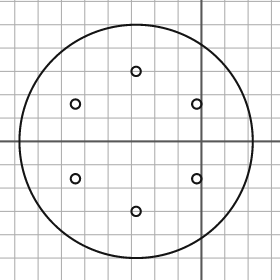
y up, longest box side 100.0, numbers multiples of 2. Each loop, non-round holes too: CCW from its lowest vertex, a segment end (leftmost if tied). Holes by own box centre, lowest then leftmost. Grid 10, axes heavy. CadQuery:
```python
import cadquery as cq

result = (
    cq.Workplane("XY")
    .moveTo(-28.0, 0.0)
    .circle(50.0)
    .moveTo(-28.0, -30.0)
    .circle(2.0)
    .moveTo(-54.0, -16.0)
    .circle(2.0)
    .moveTo(-2.0, -16.0)
    .circle(2.0)
    .moveTo(-54.0, 16.0)
    .circle(2.0)
    .moveTo(-2.0, 16.0)
    .circle(2.0)
    .moveTo(-28.0, 30.0)
    .circle(2.0)
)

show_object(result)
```